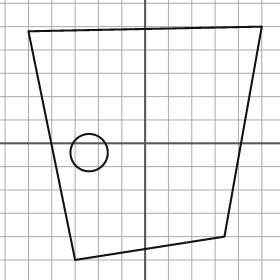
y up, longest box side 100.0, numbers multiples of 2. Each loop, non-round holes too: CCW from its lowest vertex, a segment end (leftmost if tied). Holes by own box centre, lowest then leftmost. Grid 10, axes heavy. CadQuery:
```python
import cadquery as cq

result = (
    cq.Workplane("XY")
    .moveTo(-30.0, -50.0)
    .lineTo(34.0, -40.0)
    .lineTo(50.0, 50.0)
    .lineTo(-50.0, 48.0)
    .close()
    .moveTo(-24.0, -4.0)
    .circle(8.0)
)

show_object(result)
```